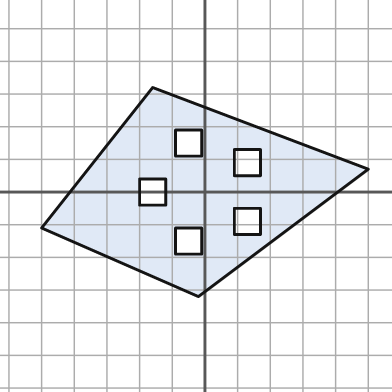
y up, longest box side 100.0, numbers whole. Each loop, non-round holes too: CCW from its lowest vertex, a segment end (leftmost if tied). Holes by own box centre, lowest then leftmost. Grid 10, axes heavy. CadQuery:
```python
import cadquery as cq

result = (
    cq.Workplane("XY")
    .moveTo(-2.0, -32.0)
    .lineTo(50.0, 7.0)
    .lineTo(-16.0, 32.0)
    .lineTo(-50.0, -11.0)
    .close()
    .moveTo(-9.0, -19.0)
    .lineTo(-1.0, -19.0)
    .lineTo(-1.0, -11.0)
    .lineTo(-9.0, -11.0)
    .close()
    .moveTo(9.0, -13.0)
    .lineTo(17.0, -13.0)
    .lineTo(17.0, -5.0)
    .lineTo(9.0, -5.0)
    .close()
    .moveTo(-20.0, -4.0)
    .lineTo(-12.0, -4.0)
    .lineTo(-12.0, 4.0)
    .lineTo(-20.0, 4.0)
    .close()
    .moveTo(9.0, 5.0)
    .lineTo(17.0, 5.0)
    .lineTo(17.0, 13.0)
    .lineTo(9.0, 13.0)
    .close()
    .moveTo(-9.0, 11.0)
    .lineTo(-1.0, 11.0)
    .lineTo(-1.0, 19.0)
    .lineTo(-9.0, 19.0)
    .close()
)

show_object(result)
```